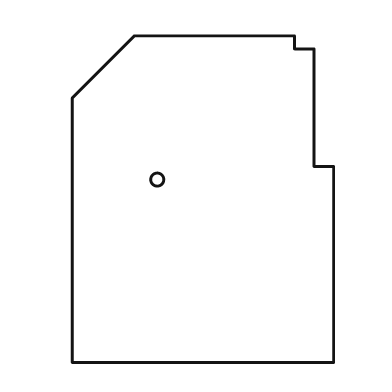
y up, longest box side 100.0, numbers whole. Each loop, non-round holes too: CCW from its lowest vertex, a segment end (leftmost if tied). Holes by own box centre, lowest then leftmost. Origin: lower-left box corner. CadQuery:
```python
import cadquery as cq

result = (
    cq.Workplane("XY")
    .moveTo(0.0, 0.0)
    .lineTo(80.0, 0.0)
    .lineTo(80.0, 60.0)
    .lineTo(74.0, 60.0)
    .lineTo(74.0, 96.0)
    .lineTo(68.0, 96.0)
    .lineTo(68.0, 100.0)
    .lineTo(19.0, 100.0)
    .lineTo(0.0, 81.0)
    .close()
    .moveTo(26.0, 56.0)
    .circle(2.0)
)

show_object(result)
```